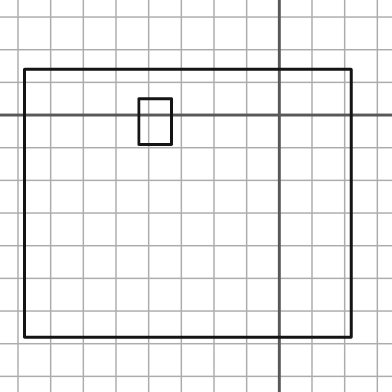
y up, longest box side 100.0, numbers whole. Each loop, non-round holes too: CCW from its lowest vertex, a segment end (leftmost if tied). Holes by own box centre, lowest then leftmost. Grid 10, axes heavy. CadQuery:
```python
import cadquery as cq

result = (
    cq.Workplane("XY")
    .moveTo(-78.0, -68.0)
    .lineTo(22.0, -68.0)
    .lineTo(22.0, 14.0)
    .lineTo(-78.0, 14.0)
    .close()
    .moveTo(-43.0, -9.0)
    .lineTo(-33.0, -9.0)
    .lineTo(-33.0, 5.0)
    .lineTo(-43.0, 5.0)
    .close()
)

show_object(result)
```